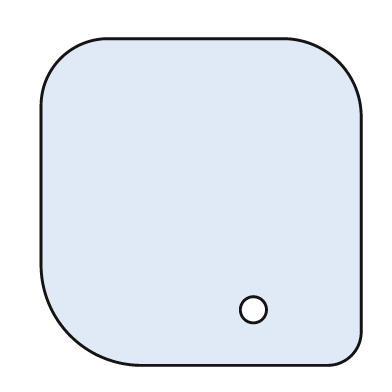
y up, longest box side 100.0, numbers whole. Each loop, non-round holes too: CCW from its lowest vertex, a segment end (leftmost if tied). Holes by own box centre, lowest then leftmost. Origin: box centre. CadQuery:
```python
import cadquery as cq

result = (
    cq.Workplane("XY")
    .moveTo(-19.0, -50.0)
    .lineTo(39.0, -50.0)
    .threePointArc((46.0, -47.0), (49.0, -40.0))
    .lineTo(49.0, 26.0)
    .threePointArc((42.0, 43.0), (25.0, 50.0))
    .lineTo(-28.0, 50.0)
    .threePointArc((-43.0, 44.0), (-49.0, 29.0))
    .lineTo(-49.0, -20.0)
    .threePointArc((-40.0, -41.0), (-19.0, -50.0))
    .close()
    .moveTo(16.0, -33.0)
    .circle(4.0)
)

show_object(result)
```